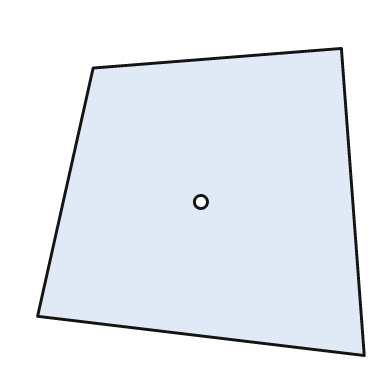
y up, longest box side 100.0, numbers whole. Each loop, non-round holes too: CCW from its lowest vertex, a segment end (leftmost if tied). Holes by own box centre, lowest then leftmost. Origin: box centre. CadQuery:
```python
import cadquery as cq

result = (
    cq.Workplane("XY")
    .moveTo(50.0, -47.0)
    .lineTo(43.0, 47.0)
    .lineTo(-33.0, 41.0)
    .lineTo(-50.0, -35.0)
    .close()
    .moveTo(0.0, 0.0)
    .circle(2.0)
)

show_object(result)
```